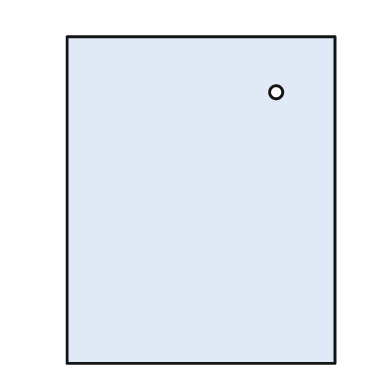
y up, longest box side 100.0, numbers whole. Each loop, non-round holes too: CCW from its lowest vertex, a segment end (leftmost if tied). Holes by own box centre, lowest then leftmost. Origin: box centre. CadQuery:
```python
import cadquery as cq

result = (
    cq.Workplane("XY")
    .moveTo(-41.0, -50.0)
    .lineTo(41.0, -50.0)
    .lineTo(41.0, 50.0)
    .lineTo(-41.0, 50.0)
    .close()
    .moveTo(23.0, 33.0)
    .circle(2.0)
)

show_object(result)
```